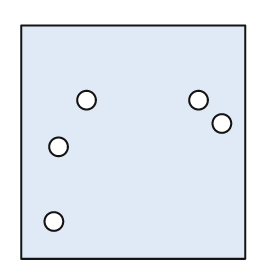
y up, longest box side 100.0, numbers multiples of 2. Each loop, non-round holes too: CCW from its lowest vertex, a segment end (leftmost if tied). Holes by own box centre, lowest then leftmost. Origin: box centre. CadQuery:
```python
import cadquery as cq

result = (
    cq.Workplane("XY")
    .moveTo(-48.0, -50.0)
    .lineTo(48.0, -50.0)
    .lineTo(48.0, 50.0)
    .lineTo(-48.0, 50.0)
    .close()
    .moveTo(-34.0, -34.0)
    .circle(4.0)
    .moveTo(-32.0, -2.0)
    .circle(4.0)
    .moveTo(38.0, 8.0)
    .circle(4.0)
    .moveTo(-20.0, 18.0)
    .circle(4.0)
    .moveTo(28.0, 18.0)
    .circle(4.0)
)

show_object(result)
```